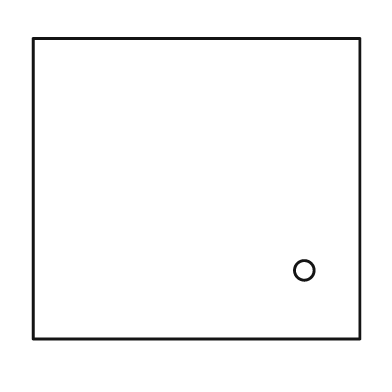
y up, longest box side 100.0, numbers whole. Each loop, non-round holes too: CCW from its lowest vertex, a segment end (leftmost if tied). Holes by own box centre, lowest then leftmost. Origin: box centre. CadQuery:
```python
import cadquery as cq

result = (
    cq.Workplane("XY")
    .moveTo(-50.0, -46.0)
    .lineTo(50.0, -46.0)
    .lineTo(50.0, 46.0)
    .lineTo(-50.0, 46.0)
    .close()
    .moveTo(33.0, -25.0)
    .circle(3.0)
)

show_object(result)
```